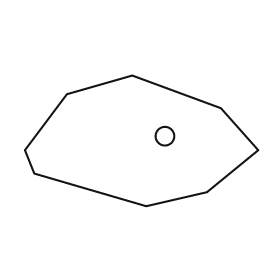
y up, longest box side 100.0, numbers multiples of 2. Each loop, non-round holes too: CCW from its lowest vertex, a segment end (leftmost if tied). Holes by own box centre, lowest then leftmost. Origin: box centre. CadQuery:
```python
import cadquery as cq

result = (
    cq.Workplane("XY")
    .moveTo(2.0, -28.0)
    .lineTo(28.0, -22.0)
    .lineTo(50.0, -4.0)
    .lineTo(34.0, 14.0)
    .lineTo(-4.0, 28.0)
    .lineTo(-32.0, 20.0)
    .lineTo(-50.0, -4.0)
    .lineTo(-46.0, -14.0)
    .close()
    .moveTo(10.0, 2.0)
    .circle(4.0)
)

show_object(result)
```